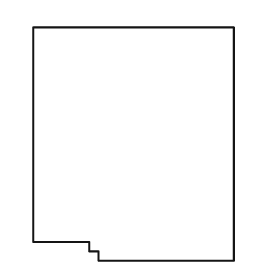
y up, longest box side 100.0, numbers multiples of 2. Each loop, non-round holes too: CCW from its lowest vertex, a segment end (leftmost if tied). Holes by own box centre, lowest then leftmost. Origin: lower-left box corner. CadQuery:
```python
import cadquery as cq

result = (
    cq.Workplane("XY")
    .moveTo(28.0, 0.0)
    .lineTo(86.0, 0.0)
    .lineTo(86.0, 100.0)
    .lineTo(0.0, 100.0)
    .lineTo(0.0, 8.0)
    .lineTo(24.0, 8.0)
    .lineTo(24.0, 4.0)
    .lineTo(28.0, 4.0)
    .close()
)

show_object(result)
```